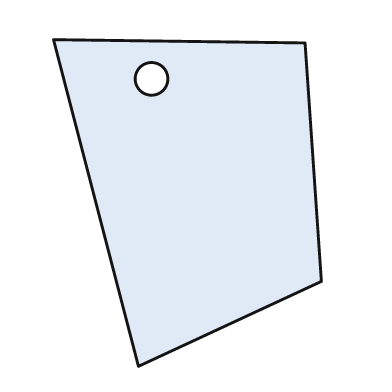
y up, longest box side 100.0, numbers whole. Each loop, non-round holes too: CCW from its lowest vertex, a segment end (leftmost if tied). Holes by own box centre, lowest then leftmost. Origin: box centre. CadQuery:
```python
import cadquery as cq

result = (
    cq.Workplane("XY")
    .moveTo(-15.0, -50.0)
    .lineTo(41.0, -24.0)
    .lineTo(36.0, 49.0)
    .lineTo(-41.0, 50.0)
    .close()
    .moveTo(-11.0, 38.0)
    .circle(5.0)
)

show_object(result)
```